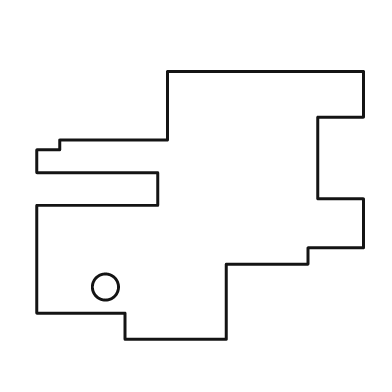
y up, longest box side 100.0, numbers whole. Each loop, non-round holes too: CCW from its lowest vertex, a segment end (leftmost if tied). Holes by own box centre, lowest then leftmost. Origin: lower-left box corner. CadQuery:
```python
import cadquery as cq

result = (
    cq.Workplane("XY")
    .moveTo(27.0, 0.0)
    .lineTo(58.0, 0.0)
    .lineTo(58.0, 23.0)
    .lineTo(83.0, 23.0)
    .lineTo(83.0, 28.0)
    .lineTo(100.0, 28.0)
    .lineTo(100.0, 43.0)
    .lineTo(86.0, 43.0)
    .lineTo(86.0, 68.0)
    .lineTo(100.0, 68.0)
    .lineTo(100.0, 82.0)
    .lineTo(40.0, 82.0)
    .lineTo(40.0, 61.0)
    .lineTo(7.0, 61.0)
    .lineTo(7.0, 58.0)
    .lineTo(0.0, 58.0)
    .lineTo(0.0, 51.0)
    .lineTo(37.0, 51.0)
    .lineTo(37.0, 41.0)
    .lineTo(0.0, 41.0)
    .lineTo(0.0, 8.0)
    .lineTo(27.0, 8.0)
    .close()
    .moveTo(21.0, 16.0)
    .circle(4.0)
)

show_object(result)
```